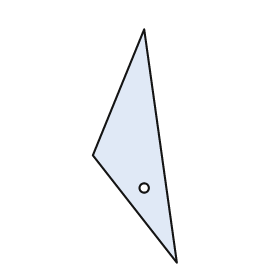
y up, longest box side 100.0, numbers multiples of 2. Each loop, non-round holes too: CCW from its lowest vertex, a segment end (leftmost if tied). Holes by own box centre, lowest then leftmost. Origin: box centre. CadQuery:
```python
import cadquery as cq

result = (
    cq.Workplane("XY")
    .moveTo(18.0, -50.0)
    .lineTo(4.0, 50.0)
    .lineTo(-18.0, -4.0)
    .close()
    .moveTo(4.0, -18.0)
    .circle(2.0)
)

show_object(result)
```